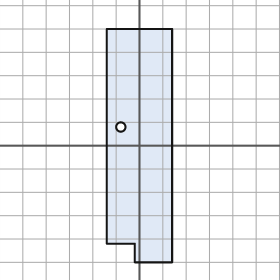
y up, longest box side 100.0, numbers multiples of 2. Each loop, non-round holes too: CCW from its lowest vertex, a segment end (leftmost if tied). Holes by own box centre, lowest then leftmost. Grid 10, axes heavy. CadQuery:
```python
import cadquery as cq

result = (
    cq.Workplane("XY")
    .moveTo(-2.0, -50.0)
    .lineTo(14.0, -50.0)
    .lineTo(14.0, 50.0)
    .lineTo(-14.0, 50.0)
    .lineTo(-14.0, -42.0)
    .lineTo(-2.0, -42.0)
    .close()
    .moveTo(-8.0, 8.0)
    .circle(2.0)
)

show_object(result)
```